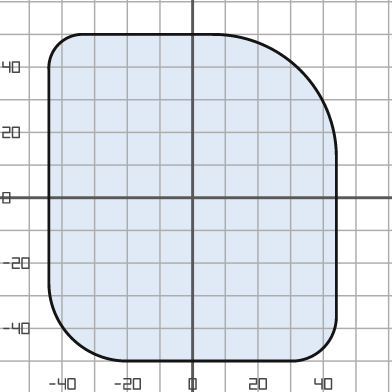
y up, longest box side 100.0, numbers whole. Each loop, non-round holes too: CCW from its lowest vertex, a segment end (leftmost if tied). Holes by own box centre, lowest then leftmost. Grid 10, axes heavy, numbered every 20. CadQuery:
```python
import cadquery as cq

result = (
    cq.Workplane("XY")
    .moveTo(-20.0, -50.0)
    .lineTo(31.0, -50.0)
    .threePointArc((40.0, -46.0), (44.0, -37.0))
    .lineTo(44.0, 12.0)
    .threePointArc((33.0, 39.0), (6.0, 50.0))
    .lineTo(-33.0, 50.0)
    .threePointArc((-41.0, 47.0), (-44.0, 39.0))
    .lineTo(-44.0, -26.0)
    .threePointArc((-37.0, -43.0), (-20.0, -50.0))
    .close()
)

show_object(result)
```